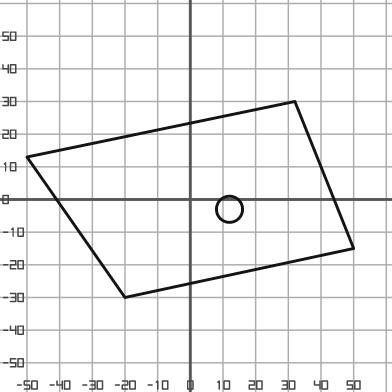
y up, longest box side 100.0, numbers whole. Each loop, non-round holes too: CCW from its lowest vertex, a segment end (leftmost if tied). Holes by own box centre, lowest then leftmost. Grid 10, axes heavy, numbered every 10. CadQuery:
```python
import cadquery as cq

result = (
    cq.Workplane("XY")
    .moveTo(-20.0, -30.0)
    .lineTo(50.0, -15.0)
    .lineTo(32.0, 30.0)
    .lineTo(-50.0, 13.0)
    .close()
    .moveTo(12.0, -3.0)
    .circle(4.0)
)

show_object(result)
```